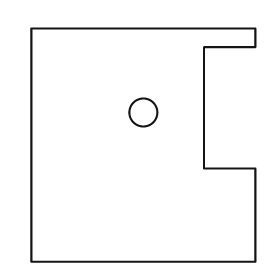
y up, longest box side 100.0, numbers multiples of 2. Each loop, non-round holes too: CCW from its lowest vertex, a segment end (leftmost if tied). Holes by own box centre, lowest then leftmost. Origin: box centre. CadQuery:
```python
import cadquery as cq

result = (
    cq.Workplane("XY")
    .moveTo(-48.0, -50.0)
    .lineTo(48.0, -50.0)
    .lineTo(48.0, -10.0)
    .lineTo(26.0, -10.0)
    .lineTo(26.0, 42.0)
    .lineTo(48.0, 42.0)
    .lineTo(48.0, 50.0)
    .lineTo(-48.0, 50.0)
    .close()
    .moveTo(0.0, 14.0)
    .circle(6.0)
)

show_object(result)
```